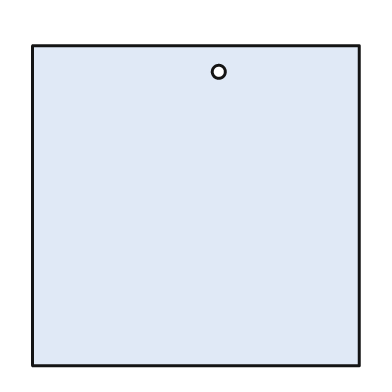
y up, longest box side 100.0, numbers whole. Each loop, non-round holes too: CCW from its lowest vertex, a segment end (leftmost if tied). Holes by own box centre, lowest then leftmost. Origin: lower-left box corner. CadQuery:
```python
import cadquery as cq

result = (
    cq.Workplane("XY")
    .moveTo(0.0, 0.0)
    .lineTo(100.0, 0.0)
    .lineTo(100.0, 98.0)
    .lineTo(0.0, 98.0)
    .close()
    .moveTo(57.0, 90.0)
    .circle(2.0)
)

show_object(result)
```